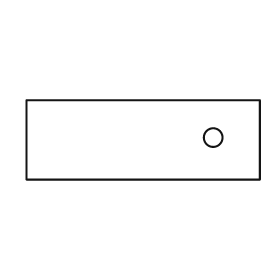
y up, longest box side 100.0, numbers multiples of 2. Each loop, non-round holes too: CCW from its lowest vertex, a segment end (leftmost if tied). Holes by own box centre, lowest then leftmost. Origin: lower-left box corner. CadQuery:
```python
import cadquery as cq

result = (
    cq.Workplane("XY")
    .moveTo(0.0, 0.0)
    .lineTo(100.0, 0.0)
    .lineTo(100.0, 34.0)
    .lineTo(0.0, 34.0)
    .close()
    .moveTo(80.0, 18.0)
    .circle(4.0)
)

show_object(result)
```